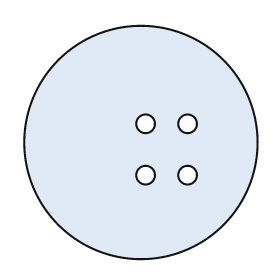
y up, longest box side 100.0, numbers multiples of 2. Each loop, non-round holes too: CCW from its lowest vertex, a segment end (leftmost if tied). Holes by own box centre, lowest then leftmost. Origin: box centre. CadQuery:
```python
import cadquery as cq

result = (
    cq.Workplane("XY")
    .moveTo(0.0, 0.0)
    .circle(50.0)
    .moveTo(2.0, -14.0)
    .circle(4.0)
    .moveTo(20.0, -14.0)
    .circle(4.0)
    .moveTo(2.0, 8.0)
    .circle(4.0)
    .moveTo(20.0, 8.0)
    .circle(4.0)
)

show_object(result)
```